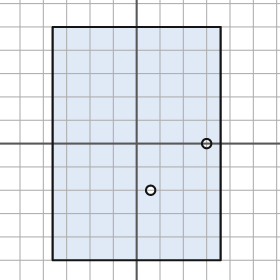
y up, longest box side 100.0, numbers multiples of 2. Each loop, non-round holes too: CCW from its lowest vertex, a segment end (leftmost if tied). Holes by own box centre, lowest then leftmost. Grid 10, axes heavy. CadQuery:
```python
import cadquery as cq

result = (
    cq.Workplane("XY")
    .moveTo(-36.0, -50.0)
    .lineTo(36.0, -50.0)
    .lineTo(36.0, 50.0)
    .lineTo(-36.0, 50.0)
    .close()
    .moveTo(6.0, -20.0)
    .circle(2.0)
    .moveTo(30.0, 0.0)
    .circle(2.0)
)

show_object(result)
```